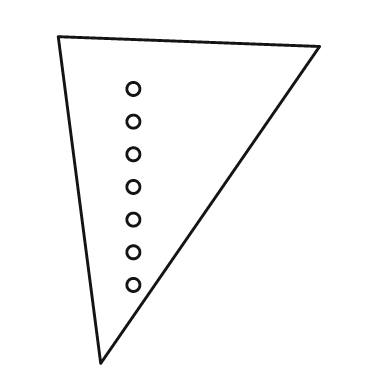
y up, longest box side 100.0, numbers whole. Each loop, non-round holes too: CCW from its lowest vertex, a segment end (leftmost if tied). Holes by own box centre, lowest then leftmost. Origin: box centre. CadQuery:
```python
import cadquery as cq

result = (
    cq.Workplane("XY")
    .moveTo(-27.0, -50.0)
    .lineTo(40.0, 47.0)
    .lineTo(-40.0, 50.0)
    .close()
    .moveTo(-17.0, -26.0)
    .circle(2.0)
    .moveTo(-17.0, -16.0)
    .circle(2.0)
    .moveTo(-17.0, -6.0)
    .circle(2.0)
    .moveTo(-17.0, 4.0)
    .circle(2.0)
    .moveTo(-17.0, 14.0)
    .circle(2.0)
    .moveTo(-17.0, 24.0)
    .circle(2.0)
    .moveTo(-17.0, 34.0)
    .circle(2.0)
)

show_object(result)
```